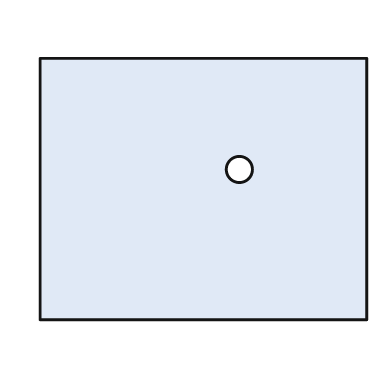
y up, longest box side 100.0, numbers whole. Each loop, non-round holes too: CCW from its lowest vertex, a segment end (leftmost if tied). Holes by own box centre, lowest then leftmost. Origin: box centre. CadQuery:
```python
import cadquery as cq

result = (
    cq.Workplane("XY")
    .moveTo(-50.0, -40.0)
    .lineTo(50.0, -40.0)
    .lineTo(50.0, 40.0)
    .lineTo(-50.0, 40.0)
    .close()
    .moveTo(11.0, 6.0)
    .circle(4.0)
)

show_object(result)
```